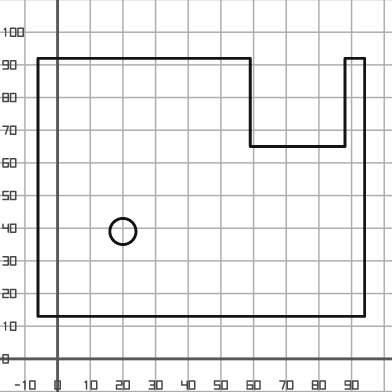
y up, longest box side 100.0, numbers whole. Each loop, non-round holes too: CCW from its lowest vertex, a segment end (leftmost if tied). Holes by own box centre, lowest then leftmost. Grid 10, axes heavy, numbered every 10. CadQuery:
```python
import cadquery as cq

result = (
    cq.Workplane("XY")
    .moveTo(-6.0, 13.0)
    .lineTo(94.0, 13.0)
    .lineTo(94.0, 92.0)
    .lineTo(88.0, 92.0)
    .lineTo(88.0, 65.0)
    .lineTo(59.0, 65.0)
    .lineTo(59.0, 92.0)
    .lineTo(-6.0, 92.0)
    .close()
    .moveTo(20.0, 39.0)
    .circle(4.0)
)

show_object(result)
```